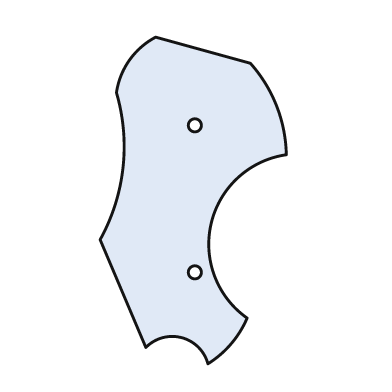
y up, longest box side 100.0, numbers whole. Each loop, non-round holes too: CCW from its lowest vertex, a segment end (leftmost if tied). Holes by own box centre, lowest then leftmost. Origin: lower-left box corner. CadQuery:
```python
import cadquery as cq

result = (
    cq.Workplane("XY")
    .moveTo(33.0, 0.0)
    .threePointArc((40.0, 6.0), (45.0, 14.0))
    .threePointArc((34.0, 43.0), (57.0, 64.0))
    .threePointArc((54.0, 79.0), (46.0, 92.0))
    .lineTo(17.0, 100.0)
    .threePointArc((9.0, 93.0), (5.0, 83.0))
    .threePointArc((7.0, 60.0), (0.0, 38.0))
    .lineTo(14.0, 5.0)
    .threePointArc((25.0, 8.0), (33.0, 0.0))
    .close()
    .moveTo(29.0, 28.0)
    .circle(2.0)
    .moveTo(29.0, 73.0)
    .circle(2.0)
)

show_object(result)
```